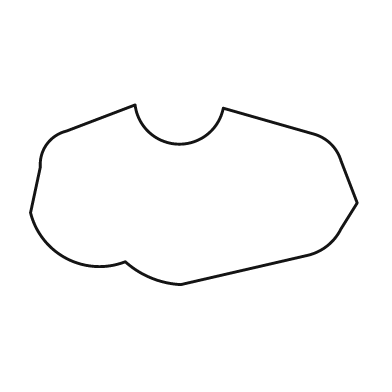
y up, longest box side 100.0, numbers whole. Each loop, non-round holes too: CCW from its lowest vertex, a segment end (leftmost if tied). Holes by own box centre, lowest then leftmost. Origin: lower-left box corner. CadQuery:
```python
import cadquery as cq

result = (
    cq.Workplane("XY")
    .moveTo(46.0, 0.0)
    .lineTo(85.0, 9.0)
    .threePointArc((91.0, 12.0), (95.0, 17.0))
    .lineTo(100.0, 25.0)
    .lineTo(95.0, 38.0)
    .threePointArc((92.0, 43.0), (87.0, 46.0))
    .lineTo(59.0, 54.0)
    .threePointArc((45.0, 43.0), (32.0, 55.0))
    .lineTo(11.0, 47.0)
    .threePointArc((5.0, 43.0), (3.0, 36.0))
    .lineTo(0.0, 22.0)
    .threePointArc((11.0, 8.0), (29.0, 7.0))
    .threePointArc((37.0, 2.0), (46.0, 0.0))
    .close()
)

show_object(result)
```